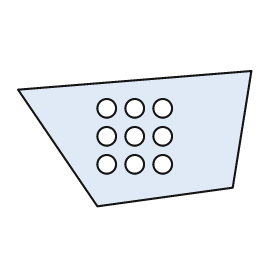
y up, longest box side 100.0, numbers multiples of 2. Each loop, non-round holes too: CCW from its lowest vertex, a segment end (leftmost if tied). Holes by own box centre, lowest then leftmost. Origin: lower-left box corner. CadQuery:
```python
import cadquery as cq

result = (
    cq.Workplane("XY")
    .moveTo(34.0, 0.0)
    .lineTo(92.0, 8.0)
    .lineTo(100.0, 58.0)
    .lineTo(0.0, 50.0)
    .close()
    .moveTo(38.0, 18.0)
    .circle(4.0)
    .moveTo(50.0, 18.0)
    .circle(4.0)
    .moveTo(62.0, 18.0)
    .circle(4.0)
    .moveTo(38.0, 30.0)
    .circle(4.0)
    .moveTo(50.0, 30.0)
    .circle(4.0)
    .moveTo(62.0, 30.0)
    .circle(4.0)
    .moveTo(38.0, 42.0)
    .circle(4.0)
    .moveTo(50.0, 42.0)
    .circle(4.0)
    .moveTo(62.0, 42.0)
    .circle(4.0)
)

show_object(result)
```